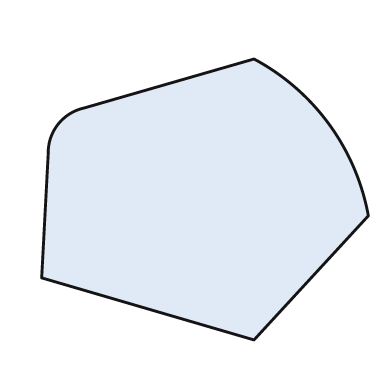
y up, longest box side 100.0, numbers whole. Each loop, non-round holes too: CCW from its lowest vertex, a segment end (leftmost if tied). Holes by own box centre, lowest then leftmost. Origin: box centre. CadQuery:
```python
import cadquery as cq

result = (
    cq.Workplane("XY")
    .moveTo(15.0, -43.0)
    .lineTo(50.0, -5.0)
    .threePointArc((38.0, 23.0), (15.0, 43.0))
    .lineTo(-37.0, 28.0)
    .threePointArc((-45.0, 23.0), (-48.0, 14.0))
    .lineTo(-50.0, -24.0)
    .close()
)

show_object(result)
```